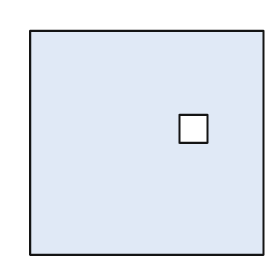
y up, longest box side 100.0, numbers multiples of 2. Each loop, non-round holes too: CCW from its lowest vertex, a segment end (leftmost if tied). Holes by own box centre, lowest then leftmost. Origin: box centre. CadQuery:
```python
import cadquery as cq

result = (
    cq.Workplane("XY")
    .moveTo(-50.0, -48.0)
    .lineTo(50.0, -48.0)
    .lineTo(50.0, 48.0)
    .lineTo(-50.0, 48.0)
    .close()
    .moveTo(14.0, 0.0)
    .lineTo(26.0, 0.0)
    .lineTo(26.0, 12.0)
    .lineTo(14.0, 12.0)
    .close()
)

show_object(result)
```